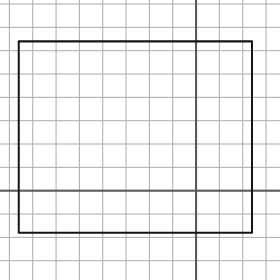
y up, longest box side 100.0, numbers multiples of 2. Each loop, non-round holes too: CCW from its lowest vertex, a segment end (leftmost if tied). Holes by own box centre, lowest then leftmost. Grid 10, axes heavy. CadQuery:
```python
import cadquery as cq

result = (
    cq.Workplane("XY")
    .moveTo(-76.0, -18.0)
    .lineTo(24.0, -18.0)
    .lineTo(24.0, 64.0)
    .lineTo(-76.0, 64.0)
    .close()
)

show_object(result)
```